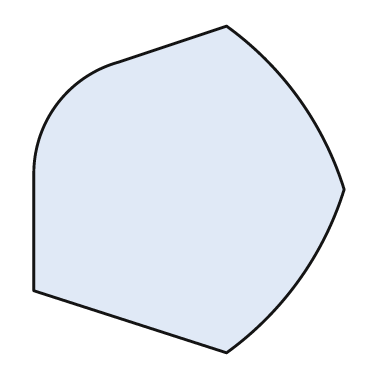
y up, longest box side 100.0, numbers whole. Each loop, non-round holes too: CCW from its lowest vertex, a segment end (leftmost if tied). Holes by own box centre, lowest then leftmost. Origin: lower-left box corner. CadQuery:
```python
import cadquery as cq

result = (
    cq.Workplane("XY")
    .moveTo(59.0, 0.0)
    .threePointArc((81.0, 22.0), (95.0, 50.0))
    .threePointArc((81.0, 78.0), (59.0, 100.0))
    .lineTo(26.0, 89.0)
    .threePointArc((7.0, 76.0), (0.0, 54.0))
    .lineTo(0.0, 19.0)
    .close()
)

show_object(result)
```